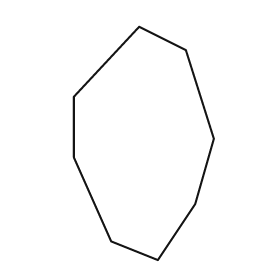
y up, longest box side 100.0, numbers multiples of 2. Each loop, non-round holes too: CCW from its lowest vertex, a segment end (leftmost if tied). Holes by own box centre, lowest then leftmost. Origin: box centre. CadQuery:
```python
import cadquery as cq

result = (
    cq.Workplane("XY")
    .moveTo(6.0, -50.0)
    .lineTo(22.0, -26.0)
    .lineTo(30.0, 2.0)
    .lineTo(18.0, 40.0)
    .lineTo(-2.0, 50.0)
    .lineTo(-30.0, 20.0)
    .lineTo(-30.0, -6.0)
    .lineTo(-14.0, -42.0)
    .close()
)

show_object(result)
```